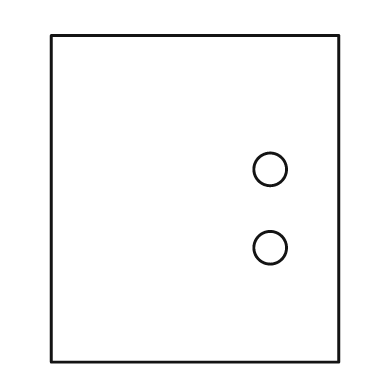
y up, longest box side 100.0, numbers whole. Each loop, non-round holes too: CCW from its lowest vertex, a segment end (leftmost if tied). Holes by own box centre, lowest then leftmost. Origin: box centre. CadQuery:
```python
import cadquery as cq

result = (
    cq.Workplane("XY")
    .moveTo(-44.0, -50.0)
    .lineTo(44.0, -50.0)
    .lineTo(44.0, 50.0)
    .lineTo(-44.0, 50.0)
    .close()
    .moveTo(23.0, -15.0)
    .circle(5.0)
    .moveTo(23.0, 9.0)
    .circle(5.0)
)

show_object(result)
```